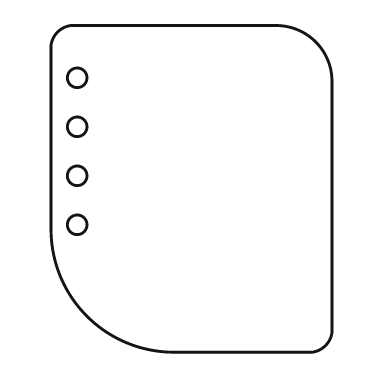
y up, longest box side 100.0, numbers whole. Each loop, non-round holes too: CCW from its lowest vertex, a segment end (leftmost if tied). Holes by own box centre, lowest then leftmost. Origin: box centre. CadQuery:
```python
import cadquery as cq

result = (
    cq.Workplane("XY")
    .moveTo(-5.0, -50.0)
    .lineTo(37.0, -50.0)
    .threePointArc((41.0, -48.0), (43.0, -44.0))
    .lineTo(43.0, 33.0)
    .threePointArc((38.0, 45.0), (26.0, 50.0))
    .lineTo(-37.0, 50.0)
    .threePointArc((-41.0, 48.0), (-43.0, 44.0))
    .lineTo(-43.0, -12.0)
    .threePointArc((-32.0, -39.0), (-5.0, -50.0))
    .close()
    .moveTo(-35.0, -11.0)
    .circle(3.0)
    .moveTo(-35.0, 4.0)
    .circle(3.0)
    .moveTo(-35.0, 19.0)
    .circle(3.0)
    .moveTo(-35.0, 34.0)
    .circle(3.0)
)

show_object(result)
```